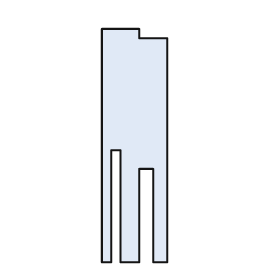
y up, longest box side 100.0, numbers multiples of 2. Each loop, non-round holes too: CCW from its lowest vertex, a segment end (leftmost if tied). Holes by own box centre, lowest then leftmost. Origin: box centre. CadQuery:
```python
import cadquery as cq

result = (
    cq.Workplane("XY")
    .moveTo(-14.0, -50.0)
    .lineTo(-10.0, -50.0)
    .lineTo(-10.0, -2.0)
    .lineTo(-6.0, -2.0)
    .lineTo(-6.0, -50.0)
    .lineTo(2.0, -50.0)
    .lineTo(2.0, -10.0)
    .lineTo(8.0, -10.0)
    .lineTo(8.0, -50.0)
    .lineTo(14.0, -50.0)
    .lineTo(14.0, 46.0)
    .lineTo(2.0, 46.0)
    .lineTo(2.0, 50.0)
    .lineTo(-14.0, 50.0)
    .close()
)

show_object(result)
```